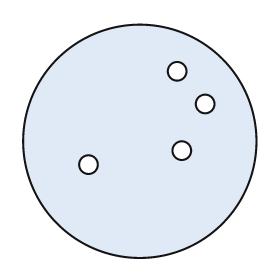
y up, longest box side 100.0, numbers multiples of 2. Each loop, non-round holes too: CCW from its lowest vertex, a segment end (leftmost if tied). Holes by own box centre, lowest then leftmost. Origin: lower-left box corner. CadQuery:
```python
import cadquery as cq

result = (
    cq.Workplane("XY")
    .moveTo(50.0, 50.0)
    .circle(50.0)
    .moveTo(28.0, 40.0)
    .circle(4.0)
    .moveTo(68.0, 46.0)
    .circle(4.0)
    .moveTo(78.0, 66.0)
    .circle(4.0)
    .moveTo(66.0, 80.0)
    .circle(4.0)
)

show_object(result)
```